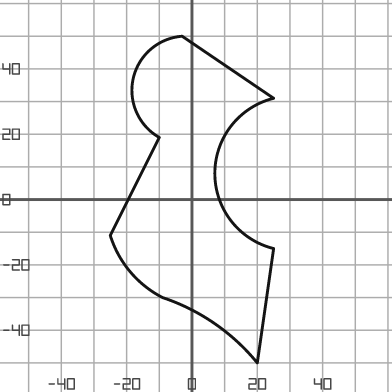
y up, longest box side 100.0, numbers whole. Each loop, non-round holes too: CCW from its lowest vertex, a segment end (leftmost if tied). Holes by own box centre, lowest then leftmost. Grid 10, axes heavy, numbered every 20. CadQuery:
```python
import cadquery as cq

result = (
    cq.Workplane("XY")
    .moveTo(20.0, -50.0)
    .lineTo(25.0, -15.0)
    .threePointArc((7.0, 8.0), (25.0, 31.0))
    .lineTo(-3.0, 50.0)
    .threePointArc((-18.0, 37.0), (-10.0, 19.0))
    .lineTo(-25.0, -11.0)
    .threePointArc((-19.0, -22.0), (-9.0, -30.0))
    .threePointArc((7.0, -38.0), (20.0, -50.0))
    .close()
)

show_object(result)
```